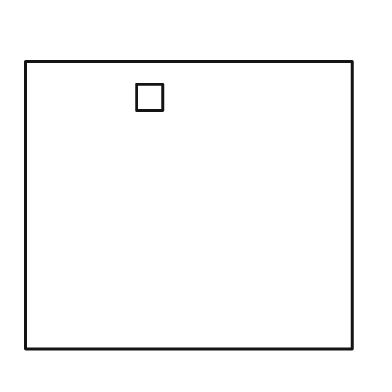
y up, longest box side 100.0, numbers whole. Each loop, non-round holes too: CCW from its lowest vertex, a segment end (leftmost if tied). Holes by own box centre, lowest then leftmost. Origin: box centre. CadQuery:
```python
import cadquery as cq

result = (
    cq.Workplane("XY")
    .moveTo(-50.0, -44.0)
    .lineTo(50.0, -44.0)
    .lineTo(50.0, 44.0)
    .lineTo(-50.0, 44.0)
    .close()
    .moveTo(-16.0, 29.0)
    .lineTo(-8.0, 29.0)
    .lineTo(-8.0, 37.0)
    .lineTo(-16.0, 37.0)
    .close()
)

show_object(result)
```